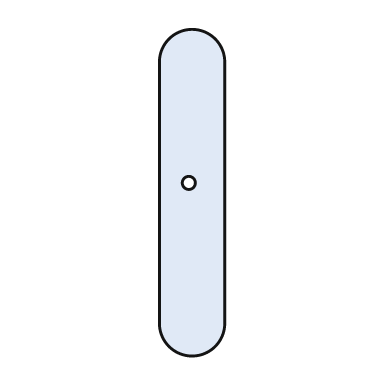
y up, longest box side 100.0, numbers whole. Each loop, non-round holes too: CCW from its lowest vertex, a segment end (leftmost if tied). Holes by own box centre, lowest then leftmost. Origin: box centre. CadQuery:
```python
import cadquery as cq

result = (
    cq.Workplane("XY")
    .moveTo(-10.0, -40.0)
    .threePointArc((0.0, -50.0), (10.0, -40.0))
    .lineTo(10.0, 40.0)
    .threePointArc((0.0, 50.0), (-10.0, 40.0))
    .close()
    .moveTo(-1.0, 3.0)
    .circle(2.0)
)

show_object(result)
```